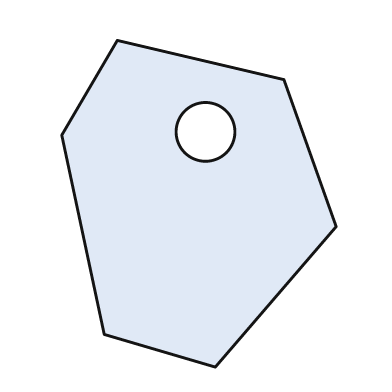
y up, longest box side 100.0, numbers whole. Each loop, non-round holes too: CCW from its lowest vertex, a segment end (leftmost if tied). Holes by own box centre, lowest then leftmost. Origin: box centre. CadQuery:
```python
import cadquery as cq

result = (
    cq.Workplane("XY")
    .moveTo(5.0, -50.0)
    .lineTo(42.0, -7.0)
    .lineTo(26.0, 38.0)
    .lineTo(-25.0, 50.0)
    .lineTo(-42.0, 21.0)
    .lineTo(-29.0, -40.0)
    .close()
    .moveTo(2.0, 22.0)
    .circle(9.0)
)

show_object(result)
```